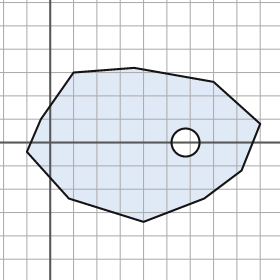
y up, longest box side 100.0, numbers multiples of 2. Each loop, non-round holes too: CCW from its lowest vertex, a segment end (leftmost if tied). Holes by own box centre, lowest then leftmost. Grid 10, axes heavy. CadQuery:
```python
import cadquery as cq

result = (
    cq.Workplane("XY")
    .moveTo(40.0, -34.0)
    .lineTo(66.0, -24.0)
    .lineTo(82.0, -12.0)
    .lineTo(90.0, 8.0)
    .lineTo(70.0, 26.0)
    .lineTo(36.0, 32.0)
    .lineTo(10.0, 30.0)
    .lineTo(-4.0, 10.0)
    .lineTo(-10.0, -4.0)
    .lineTo(8.0, -24.0)
    .close()
    .moveTo(58.0, 0.0)
    .circle(6.0)
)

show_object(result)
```